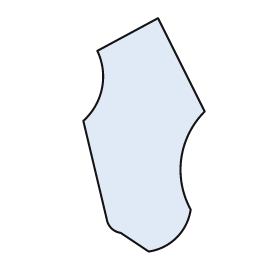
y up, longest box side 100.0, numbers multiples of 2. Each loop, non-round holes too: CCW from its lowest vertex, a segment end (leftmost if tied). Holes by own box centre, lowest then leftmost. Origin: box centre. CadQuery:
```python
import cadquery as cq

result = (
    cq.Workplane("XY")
    .moveTo(2.0, -50.0)
    .threePointArc((14.0, -44.0), (20.0, -32.0))
    .threePointArc((16.0, -10.0), (26.0, 10.0))
    .lineTo(6.0, 50.0)
    .lineTo(-20.0, 36.0)
    .threePointArc((-18.0, 20.0), (-26.0, 6.0))
    .lineTo(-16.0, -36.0)
    .threePointArc((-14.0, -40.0), (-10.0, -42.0))
    .close()
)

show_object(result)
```